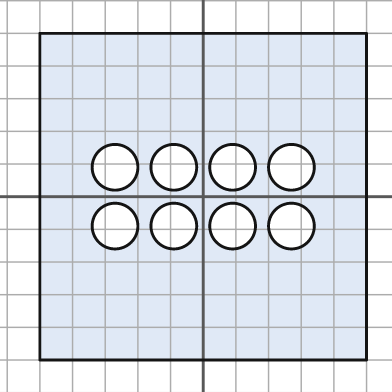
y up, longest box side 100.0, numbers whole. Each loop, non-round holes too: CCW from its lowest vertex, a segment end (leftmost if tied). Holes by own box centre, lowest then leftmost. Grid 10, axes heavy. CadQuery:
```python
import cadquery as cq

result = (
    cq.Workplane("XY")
    .moveTo(-50.0, -50.0)
    .lineTo(50.0, -50.0)
    .lineTo(50.0, 50.0)
    .lineTo(-50.0, 50.0)
    .close()
    .moveTo(-27.0, -9.0)
    .circle(7.0)
    .moveTo(-9.0, -9.0)
    .circle(7.0)
    .moveTo(9.0, -9.0)
    .circle(7.0)
    .moveTo(27.0, -9.0)
    .circle(7.0)
    .moveTo(-27.0, 9.0)
    .circle(7.0)
    .moveTo(-9.0, 9.0)
    .circle(7.0)
    .moveTo(9.0, 9.0)
    .circle(7.0)
    .moveTo(27.0, 9.0)
    .circle(7.0)
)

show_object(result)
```